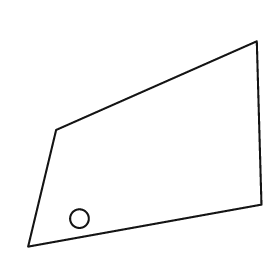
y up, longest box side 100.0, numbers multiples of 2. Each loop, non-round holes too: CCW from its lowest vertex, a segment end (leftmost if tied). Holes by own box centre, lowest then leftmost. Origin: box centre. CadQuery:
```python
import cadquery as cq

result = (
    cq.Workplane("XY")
    .moveTo(-50.0, -44.0)
    .lineTo(50.0, -26.0)
    .lineTo(48.0, 44.0)
    .lineTo(-38.0, 6.0)
    .close()
    .moveTo(-28.0, -32.0)
    .circle(4.0)
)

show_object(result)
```